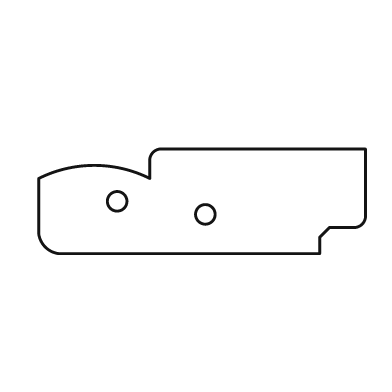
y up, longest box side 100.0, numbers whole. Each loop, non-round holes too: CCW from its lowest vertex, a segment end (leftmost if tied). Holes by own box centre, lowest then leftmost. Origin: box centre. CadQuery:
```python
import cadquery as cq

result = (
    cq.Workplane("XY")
    .moveTo(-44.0, -16.0)
    .lineTo(36.0, -16.0)
    .lineTo(36.0, -11.0)
    .lineTo(39.0, -8.0)
    .lineTo(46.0, -8.0)
    .threePointArc((49.0, -7.0), (50.0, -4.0))
    .lineTo(50.0, 16.0)
    .lineTo(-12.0, 16.0)
    .threePointArc((-15.0, 15.0), (-16.0, 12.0))
    .lineTo(-16.0, 7.0)
    .threePointArc((-33.0, 11.0), (-50.0, 7.0))
    .lineTo(-50.0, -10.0)
    .threePointArc((-48.0, -14.0), (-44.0, -16.0))
    .close()
    .moveTo(1.0, -4.0)
    .circle(3.0)
    .moveTo(-26.0, 0.0)
    .circle(3.0)
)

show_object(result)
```